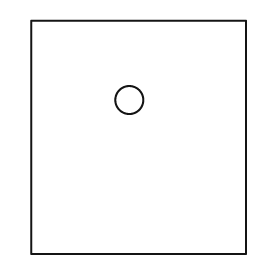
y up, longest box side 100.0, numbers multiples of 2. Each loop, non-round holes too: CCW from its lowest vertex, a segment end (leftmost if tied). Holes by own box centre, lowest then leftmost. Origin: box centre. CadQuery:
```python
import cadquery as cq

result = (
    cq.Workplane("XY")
    .moveTo(-46.0, -50.0)
    .lineTo(46.0, -50.0)
    .lineTo(46.0, 50.0)
    .lineTo(-46.0, 50.0)
    .close()
    .moveTo(-4.0, 16.0)
    .circle(6.0)
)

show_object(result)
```